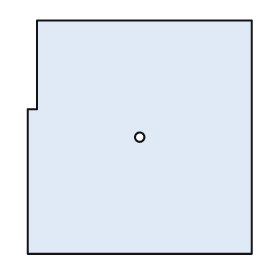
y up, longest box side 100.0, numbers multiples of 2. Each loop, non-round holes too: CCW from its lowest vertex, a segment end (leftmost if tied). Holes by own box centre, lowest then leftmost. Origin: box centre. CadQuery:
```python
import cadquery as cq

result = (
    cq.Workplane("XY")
    .moveTo(-48.0, -50.0)
    .lineTo(48.0, -50.0)
    .lineTo(48.0, 50.0)
    .lineTo(-44.0, 50.0)
    .lineTo(-44.0, 12.0)
    .lineTo(-48.0, 12.0)
    .close()
    .moveTo(0.0, 0.0)
    .circle(2.0)
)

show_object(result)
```